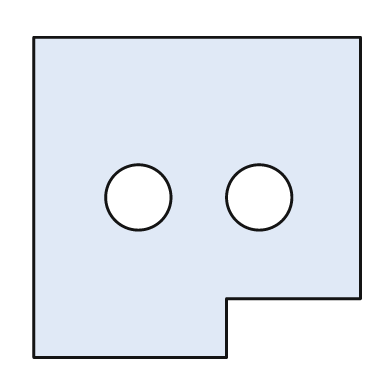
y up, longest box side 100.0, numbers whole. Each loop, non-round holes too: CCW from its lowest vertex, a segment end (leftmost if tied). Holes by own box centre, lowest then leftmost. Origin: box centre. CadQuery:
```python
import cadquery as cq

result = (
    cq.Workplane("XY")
    .moveTo(-50.0, -49.0)
    .lineTo(9.0, -49.0)
    .lineTo(9.0, -31.0)
    .lineTo(50.0, -31.0)
    .lineTo(50.0, 49.0)
    .lineTo(-50.0, 49.0)
    .close()
    .moveTo(-18.0, 0.0)
    .circle(10.0)
    .moveTo(19.0, 0.0)
    .circle(10.0)
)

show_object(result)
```